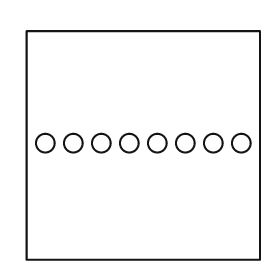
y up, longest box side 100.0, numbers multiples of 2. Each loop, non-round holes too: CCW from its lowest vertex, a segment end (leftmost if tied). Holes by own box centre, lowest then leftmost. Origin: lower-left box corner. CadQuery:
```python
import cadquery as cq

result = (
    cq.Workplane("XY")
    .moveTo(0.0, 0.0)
    .lineTo(100.0, 0.0)
    .lineTo(100.0, 98.0)
    .lineTo(0.0, 98.0)
    .close()
    .moveTo(8.0, 50.0)
    .circle(4.0)
    .moveTo(20.0, 50.0)
    .circle(4.0)
    .moveTo(32.0, 50.0)
    .circle(4.0)
    .moveTo(44.0, 50.0)
    .circle(4.0)
    .moveTo(56.0, 50.0)
    .circle(4.0)
    .moveTo(68.0, 50.0)
    .circle(4.0)
    .moveTo(80.0, 50.0)
    .circle(4.0)
    .moveTo(92.0, 50.0)
    .circle(4.0)
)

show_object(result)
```